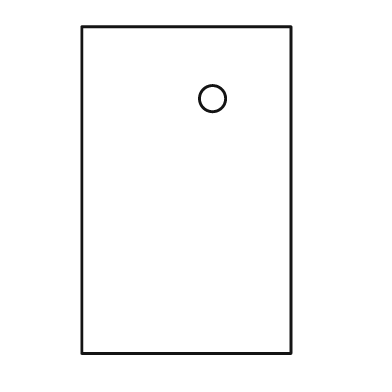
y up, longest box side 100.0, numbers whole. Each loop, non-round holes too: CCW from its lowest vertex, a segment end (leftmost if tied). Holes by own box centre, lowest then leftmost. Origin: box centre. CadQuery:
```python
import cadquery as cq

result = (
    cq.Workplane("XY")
    .moveTo(-32.0, -50.0)
    .lineTo(32.0, -50.0)
    .lineTo(32.0, 50.0)
    .lineTo(-32.0, 50.0)
    .close()
    .moveTo(8.0, 28.0)
    .circle(4.0)
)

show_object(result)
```